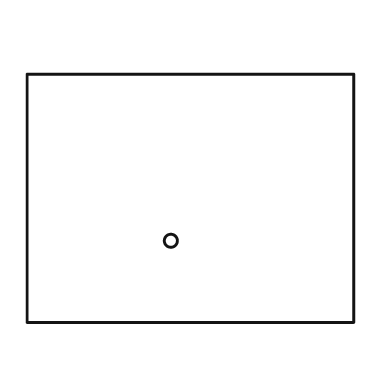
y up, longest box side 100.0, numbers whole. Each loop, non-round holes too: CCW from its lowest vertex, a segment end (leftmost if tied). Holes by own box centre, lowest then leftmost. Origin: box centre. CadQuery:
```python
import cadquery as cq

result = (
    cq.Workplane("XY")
    .moveTo(-50.0, -38.0)
    .lineTo(50.0, -38.0)
    .lineTo(50.0, 38.0)
    .lineTo(-50.0, 38.0)
    .close()
    .moveTo(-6.0, -13.0)
    .circle(2.0)
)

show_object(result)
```